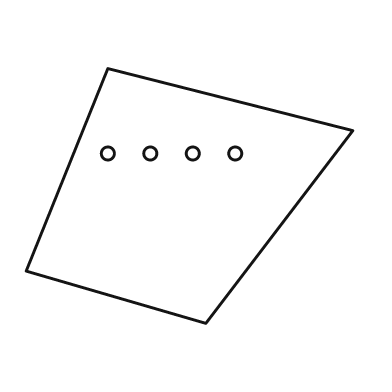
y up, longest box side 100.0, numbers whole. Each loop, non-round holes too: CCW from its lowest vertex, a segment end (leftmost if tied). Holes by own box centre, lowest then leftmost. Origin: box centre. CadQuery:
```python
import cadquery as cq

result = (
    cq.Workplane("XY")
    .moveTo(5.0, -39.0)
    .lineTo(50.0, 20.0)
    .lineTo(-25.0, 39.0)
    .lineTo(-50.0, -23.0)
    .close()
    .moveTo(-25.0, 13.0)
    .circle(2.0)
    .moveTo(-12.0, 13.0)
    .circle(2.0)
    .moveTo(1.0, 13.0)
    .circle(2.0)
    .moveTo(14.0, 13.0)
    .circle(2.0)
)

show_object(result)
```